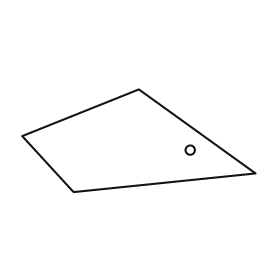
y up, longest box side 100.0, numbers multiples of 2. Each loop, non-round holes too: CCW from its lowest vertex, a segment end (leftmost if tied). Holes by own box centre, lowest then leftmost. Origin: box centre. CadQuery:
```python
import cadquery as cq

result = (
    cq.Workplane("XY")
    .moveTo(-28.0, -22.0)
    .lineTo(50.0, -14.0)
    .lineTo(0.0, 22.0)
    .lineTo(-50.0, 2.0)
    .close()
    .moveTo(22.0, -4.0)
    .circle(2.0)
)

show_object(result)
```